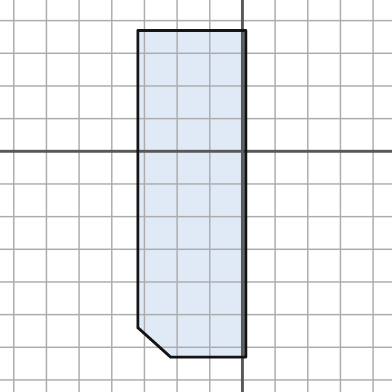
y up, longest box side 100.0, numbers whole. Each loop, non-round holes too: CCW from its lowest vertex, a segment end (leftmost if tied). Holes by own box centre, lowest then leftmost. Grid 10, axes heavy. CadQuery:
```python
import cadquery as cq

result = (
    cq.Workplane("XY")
    .moveTo(-22.0, -63.0)
    .lineTo(1.0, -63.0)
    .lineTo(1.0, 37.0)
    .lineTo(-32.0, 37.0)
    .lineTo(-32.0, -54.0)
    .close()
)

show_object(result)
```